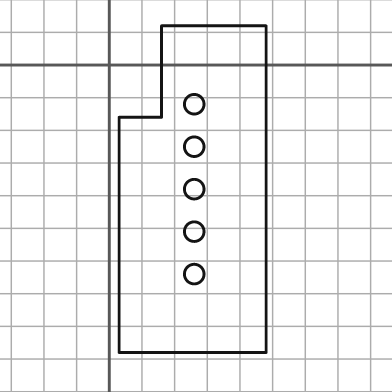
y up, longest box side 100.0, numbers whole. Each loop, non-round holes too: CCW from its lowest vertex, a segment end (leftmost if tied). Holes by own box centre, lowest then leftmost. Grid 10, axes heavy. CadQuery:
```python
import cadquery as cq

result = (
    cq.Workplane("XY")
    .moveTo(3.0, -88.0)
    .lineTo(48.0, -88.0)
    .lineTo(48.0, 12.0)
    .lineTo(16.0, 12.0)
    .lineTo(16.0, -16.0)
    .lineTo(3.0, -16.0)
    .close()
    .moveTo(26.0, -64.0)
    .circle(3.0)
    .moveTo(26.0, -51.0)
    .circle(3.0)
    .moveTo(26.0, -38.0)
    .circle(3.0)
    .moveTo(26.0, -25.0)
    .circle(3.0)
    .moveTo(26.0, -12.0)
    .circle(3.0)
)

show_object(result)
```